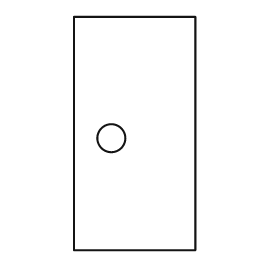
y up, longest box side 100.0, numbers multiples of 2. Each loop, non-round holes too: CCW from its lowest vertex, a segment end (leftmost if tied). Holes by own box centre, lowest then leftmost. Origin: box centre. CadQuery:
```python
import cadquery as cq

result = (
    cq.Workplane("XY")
    .moveTo(-26.0, -50.0)
    .lineTo(26.0, -50.0)
    .lineTo(26.0, 50.0)
    .lineTo(-26.0, 50.0)
    .close()
    .moveTo(-10.0, -2.0)
    .circle(6.0)
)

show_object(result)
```